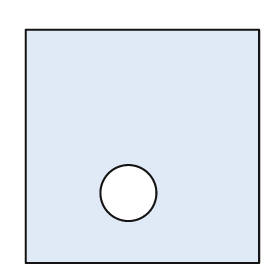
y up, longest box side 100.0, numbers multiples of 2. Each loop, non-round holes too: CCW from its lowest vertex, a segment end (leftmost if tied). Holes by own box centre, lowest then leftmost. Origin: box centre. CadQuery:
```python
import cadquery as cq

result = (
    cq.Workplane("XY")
    .moveTo(-50.0, -50.0)
    .lineTo(50.0, -50.0)
    .lineTo(50.0, 50.0)
    .lineTo(-50.0, 50.0)
    .close()
    .moveTo(-6.0, -20.0)
    .circle(12.0)
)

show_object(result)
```